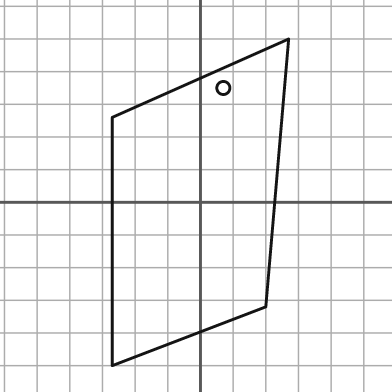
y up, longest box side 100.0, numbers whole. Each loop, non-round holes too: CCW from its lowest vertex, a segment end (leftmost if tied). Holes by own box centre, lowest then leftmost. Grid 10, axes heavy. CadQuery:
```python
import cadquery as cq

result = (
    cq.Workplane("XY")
    .moveTo(-27.0, -50.0)
    .lineTo(20.0, -32.0)
    .lineTo(27.0, 50.0)
    .lineTo(-27.0, 26.0)
    .close()
    .moveTo(7.0, 35.0)
    .circle(2.0)
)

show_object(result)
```